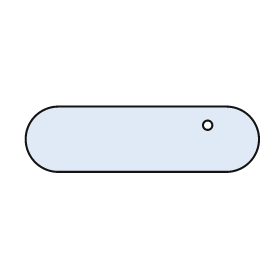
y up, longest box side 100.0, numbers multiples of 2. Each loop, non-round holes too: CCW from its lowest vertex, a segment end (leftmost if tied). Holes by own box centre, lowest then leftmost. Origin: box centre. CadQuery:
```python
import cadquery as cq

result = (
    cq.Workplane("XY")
    .moveTo(-36.0, -14.0)
    .lineTo(36.0, -14.0)
    .threePointArc((50.0, 0.0), (36.0, 14.0))
    .lineTo(-36.0, 14.0)
    .threePointArc((-50.0, 0.0), (-36.0, -14.0))
    .close()
    .moveTo(28.0, 6.0)
    .circle(2.0)
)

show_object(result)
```